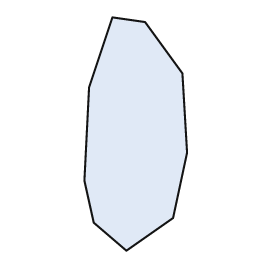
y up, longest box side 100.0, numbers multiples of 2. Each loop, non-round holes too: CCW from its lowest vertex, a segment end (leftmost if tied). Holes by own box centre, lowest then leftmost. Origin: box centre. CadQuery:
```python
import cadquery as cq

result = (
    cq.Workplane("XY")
    .moveTo(-4.0, -50.0)
    .lineTo(16.0, -36.0)
    .lineTo(22.0, -8.0)
    .lineTo(20.0, 26.0)
    .lineTo(4.0, 48.0)
    .lineTo(-10.0, 50.0)
    .lineTo(-20.0, 20.0)
    .lineTo(-22.0, -20.0)
    .lineTo(-18.0, -38.0)
    .close()
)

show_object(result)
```